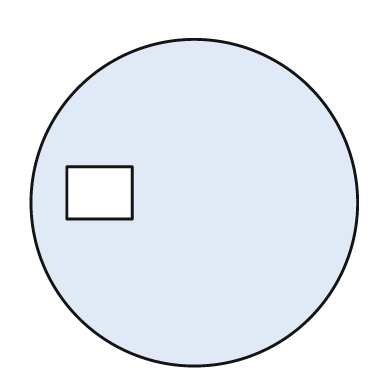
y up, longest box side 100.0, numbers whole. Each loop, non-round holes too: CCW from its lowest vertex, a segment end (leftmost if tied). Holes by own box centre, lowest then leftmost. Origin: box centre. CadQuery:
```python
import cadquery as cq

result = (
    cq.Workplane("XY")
    .moveTo(0.0, 0.0)
    .circle(50.0)
    .moveTo(-39.0, -5.0)
    .lineTo(-19.0, -5.0)
    .lineTo(-19.0, 11.0)
    .lineTo(-39.0, 11.0)
    .close()
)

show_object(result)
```